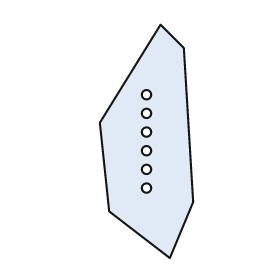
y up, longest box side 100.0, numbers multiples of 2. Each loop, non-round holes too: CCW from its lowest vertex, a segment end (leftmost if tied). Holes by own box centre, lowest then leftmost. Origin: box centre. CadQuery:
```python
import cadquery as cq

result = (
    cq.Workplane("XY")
    .moveTo(10.0, -50.0)
    .lineTo(20.0, -26.0)
    .lineTo(16.0, 40.0)
    .lineTo(6.0, 50.0)
    .lineTo(-20.0, 8.0)
    .lineTo(-16.0, -30.0)
    .close()
    .moveTo(0.0, -20.0)
    .circle(2.0)
    .moveTo(0.0, -12.0)
    .circle(2.0)
    .moveTo(0.0, -4.0)
    .circle(2.0)
    .moveTo(0.0, 4.0)
    .circle(2.0)
    .moveTo(0.0, 12.0)
    .circle(2.0)
    .moveTo(0.0, 20.0)
    .circle(2.0)
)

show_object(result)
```